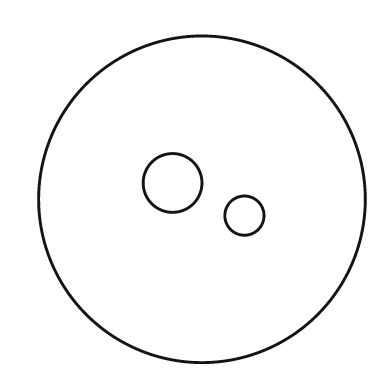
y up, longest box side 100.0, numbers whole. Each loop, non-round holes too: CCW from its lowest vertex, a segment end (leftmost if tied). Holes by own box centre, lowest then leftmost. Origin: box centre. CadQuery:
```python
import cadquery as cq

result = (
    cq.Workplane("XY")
    .moveTo(0.0, 0.0)
    .circle(50.0)
    .moveTo(13.0, -5.0)
    .circle(6.0)
    .moveTo(-9.0, 5.0)
    .circle(9.0)
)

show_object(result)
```